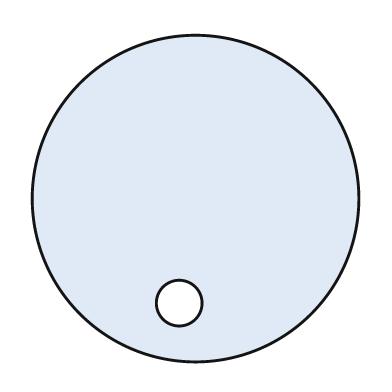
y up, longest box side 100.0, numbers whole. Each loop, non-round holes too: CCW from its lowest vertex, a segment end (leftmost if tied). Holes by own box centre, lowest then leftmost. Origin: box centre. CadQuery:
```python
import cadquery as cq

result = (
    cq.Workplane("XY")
    .moveTo(0.0, 0.0)
    .circle(50.0)
    .moveTo(-5.0, -32.0)
    .circle(7.0)
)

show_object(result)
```